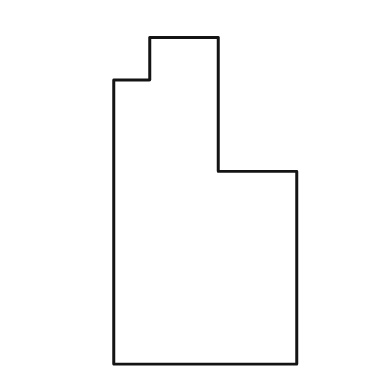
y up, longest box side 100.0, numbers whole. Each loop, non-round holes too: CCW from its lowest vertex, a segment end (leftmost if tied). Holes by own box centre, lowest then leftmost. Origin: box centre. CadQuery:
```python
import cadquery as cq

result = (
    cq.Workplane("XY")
    .moveTo(-28.0, -50.0)
    .lineTo(28.0, -50.0)
    .lineTo(28.0, 9.0)
    .lineTo(4.0, 9.0)
    .lineTo(4.0, 50.0)
    .lineTo(-17.0, 50.0)
    .lineTo(-17.0, 37.0)
    .lineTo(-28.0, 37.0)
    .close()
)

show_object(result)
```